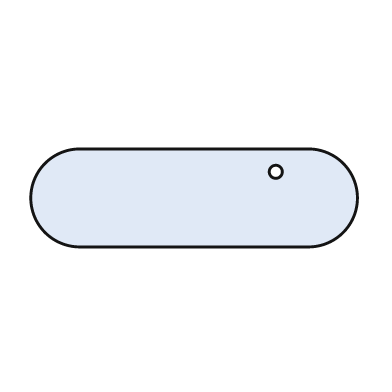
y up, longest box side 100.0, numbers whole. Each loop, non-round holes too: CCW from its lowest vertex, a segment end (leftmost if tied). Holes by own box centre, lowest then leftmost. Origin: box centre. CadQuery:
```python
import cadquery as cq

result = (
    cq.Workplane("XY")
    .moveTo(-35.0, -15.0)
    .lineTo(35.0, -15.0)
    .threePointArc((50.0, 0.0), (35.0, 15.0))
    .lineTo(-35.0, 15.0)
    .threePointArc((-50.0, 0.0), (-35.0, -15.0))
    .close()
    .moveTo(25.0, 8.0)
    .circle(2.0)
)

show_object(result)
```